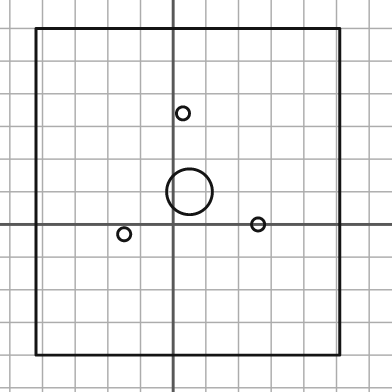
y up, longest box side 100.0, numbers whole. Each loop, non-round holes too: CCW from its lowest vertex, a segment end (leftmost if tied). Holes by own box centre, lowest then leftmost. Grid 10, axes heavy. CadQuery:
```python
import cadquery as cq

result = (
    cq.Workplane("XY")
    .moveTo(-42.0, -40.0)
    .lineTo(51.0, -40.0)
    .lineTo(51.0, 60.0)
    .lineTo(-42.0, 60.0)
    .close()
    .moveTo(-15.0, -3.0)
    .circle(2.0)
    .moveTo(26.0, 0.0)
    .circle(2.0)
    .moveTo(5.0, 10.0)
    .circle(7.0)
    .moveTo(3.0, 34.0)
    .circle(2.0)
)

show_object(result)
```